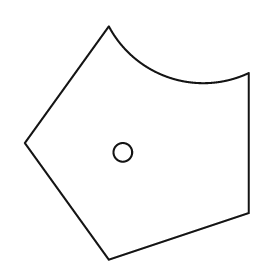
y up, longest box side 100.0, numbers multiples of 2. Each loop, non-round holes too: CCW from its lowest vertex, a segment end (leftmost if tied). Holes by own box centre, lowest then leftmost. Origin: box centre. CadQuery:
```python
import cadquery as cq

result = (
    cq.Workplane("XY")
    .moveTo(-12.0, -50.0)
    .lineTo(48.0, -30.0)
    .lineTo(48.0, 30.0)
    .threePointArc((14.0, 28.0), (-12.0, 50.0))
    .lineTo(-48.0, 0.0)
    .close()
    .moveTo(-6.0, -4.0)
    .circle(4.0)
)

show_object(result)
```